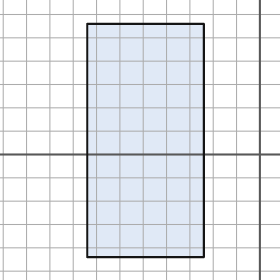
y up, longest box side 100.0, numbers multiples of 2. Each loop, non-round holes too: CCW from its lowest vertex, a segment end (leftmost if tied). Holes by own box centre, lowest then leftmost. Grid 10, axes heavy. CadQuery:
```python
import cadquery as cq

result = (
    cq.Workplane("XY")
    .moveTo(-74.0, -44.0)
    .lineTo(-24.0, -44.0)
    .lineTo(-24.0, 56.0)
    .lineTo(-74.0, 56.0)
    .close()
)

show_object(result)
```